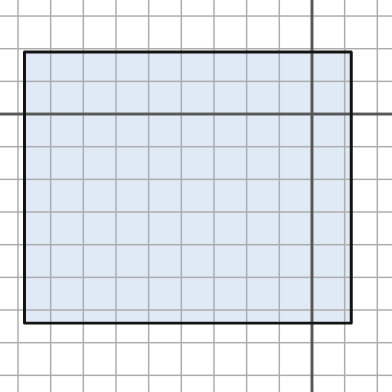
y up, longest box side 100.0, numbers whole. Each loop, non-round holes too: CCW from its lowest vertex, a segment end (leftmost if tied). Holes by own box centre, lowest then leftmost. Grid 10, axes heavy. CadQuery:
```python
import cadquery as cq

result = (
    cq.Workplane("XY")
    .moveTo(-88.0, -64.0)
    .lineTo(12.0, -64.0)
    .lineTo(12.0, 19.0)
    .lineTo(-88.0, 19.0)
    .close()
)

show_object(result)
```